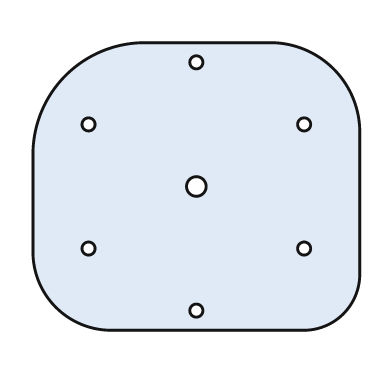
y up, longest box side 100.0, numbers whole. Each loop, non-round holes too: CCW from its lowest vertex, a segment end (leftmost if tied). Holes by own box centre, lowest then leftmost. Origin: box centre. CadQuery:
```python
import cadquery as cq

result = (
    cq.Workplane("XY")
    .moveTo(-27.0, -44.0)
    .lineTo(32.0, -44.0)
    .threePointArc((45.0, -39.0), (50.0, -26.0))
    .lineTo(50.0, 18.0)
    .threePointArc((42.0, 36.0), (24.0, 44.0))
    .lineTo(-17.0, 44.0)
    .threePointArc((-40.0, 34.0), (-50.0, 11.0))
    .lineTo(-50.0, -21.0)
    .threePointArc((-43.0, -37.0), (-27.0, -44.0))
    .close()
    .moveTo(0.0, -38.0)
    .circle(2.0)
    .moveTo(-33.0, -19.0)
    .circle(2.0)
    .moveTo(33.0, -19.0)
    .circle(2.0)
    .moveTo(0.0, 0.0)
    .circle(3.0)
    .moveTo(-33.0, 19.0)
    .circle(2.0)
    .moveTo(33.0, 19.0)
    .circle(2.0)
    .moveTo(0.0, 38.0)
    .circle(2.0)
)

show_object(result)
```